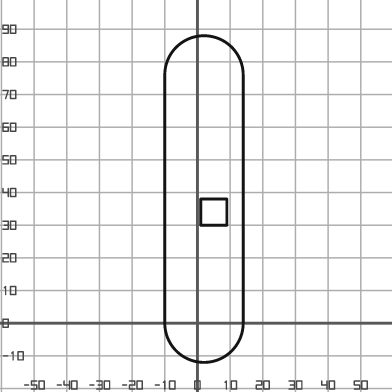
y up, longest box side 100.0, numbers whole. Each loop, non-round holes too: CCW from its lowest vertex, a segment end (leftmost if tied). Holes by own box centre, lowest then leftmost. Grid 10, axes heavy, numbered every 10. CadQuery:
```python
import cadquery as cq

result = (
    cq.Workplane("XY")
    .moveTo(-10.0, 0.0)
    .threePointArc((2.0, -12.0), (14.0, 0.0))
    .lineTo(14.0, 76.0)
    .threePointArc((2.0, 88.0), (-10.0, 76.0))
    .close()
    .moveTo(1.0, 30.0)
    .lineTo(9.0, 30.0)
    .lineTo(9.0, 38.0)
    .lineTo(1.0, 38.0)
    .close()
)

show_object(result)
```